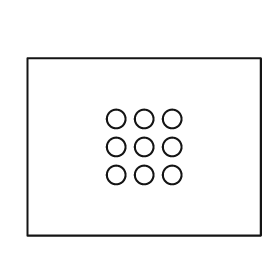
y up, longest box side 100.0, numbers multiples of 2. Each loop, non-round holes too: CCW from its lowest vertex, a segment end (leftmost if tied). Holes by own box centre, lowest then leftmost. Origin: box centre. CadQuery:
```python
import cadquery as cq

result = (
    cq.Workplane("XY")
    .moveTo(-50.0, -38.0)
    .lineTo(50.0, -38.0)
    .lineTo(50.0, 38.0)
    .lineTo(-50.0, 38.0)
    .close()
    .moveTo(-12.0, -12.0)
    .circle(4.0)
    .moveTo(0.0, -12.0)
    .circle(4.0)
    .moveTo(12.0, -12.0)
    .circle(4.0)
    .moveTo(-12.0, 0.0)
    .circle(4.0)
    .moveTo(0.0, 0.0)
    .circle(4.0)
    .moveTo(12.0, 0.0)
    .circle(4.0)
    .moveTo(-12.0, 12.0)
    .circle(4.0)
    .moveTo(0.0, 12.0)
    .circle(4.0)
    .moveTo(12.0, 12.0)
    .circle(4.0)
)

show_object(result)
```